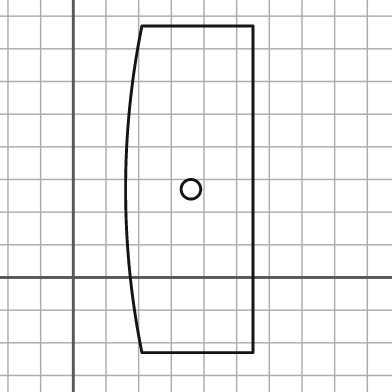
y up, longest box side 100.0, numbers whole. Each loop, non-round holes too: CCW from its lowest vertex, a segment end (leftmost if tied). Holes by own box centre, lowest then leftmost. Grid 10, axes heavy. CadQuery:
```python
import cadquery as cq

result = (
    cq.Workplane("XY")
    .moveTo(21.0, -23.0)
    .lineTo(55.0, -23.0)
    .lineTo(55.0, 77.0)
    .lineTo(21.0, 77.0)
    .threePointArc((16.0, 27.0), (21.0, -23.0))
    .close()
    .moveTo(36.0, 27.0)
    .circle(3.0)
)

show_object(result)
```